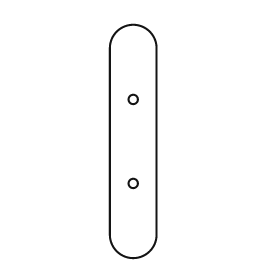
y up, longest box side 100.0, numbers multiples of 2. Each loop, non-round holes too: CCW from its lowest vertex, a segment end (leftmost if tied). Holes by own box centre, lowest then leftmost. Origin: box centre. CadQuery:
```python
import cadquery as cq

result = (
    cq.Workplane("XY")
    .moveTo(-10.0, -40.0)
    .threePointArc((0.0, -50.0), (10.0, -40.0))
    .lineTo(10.0, 40.0)
    .threePointArc((0.0, 50.0), (-10.0, 40.0))
    .close()
    .moveTo(0.0, -18.0)
    .circle(2.0)
    .moveTo(0.0, 18.0)
    .circle(2.0)
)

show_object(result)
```